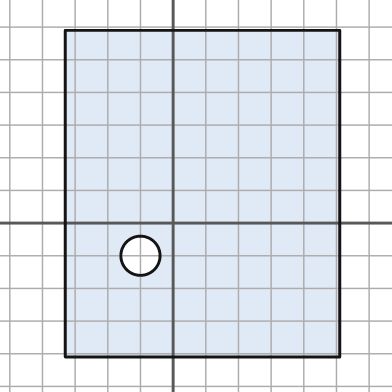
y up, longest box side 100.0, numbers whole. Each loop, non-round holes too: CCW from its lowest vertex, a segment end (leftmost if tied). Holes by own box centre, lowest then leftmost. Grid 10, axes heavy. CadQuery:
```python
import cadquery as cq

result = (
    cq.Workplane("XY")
    .moveTo(-33.0, -41.0)
    .lineTo(51.0, -41.0)
    .lineTo(51.0, 59.0)
    .lineTo(-33.0, 59.0)
    .close()
    .moveTo(-10.0, -10.0)
    .circle(6.0)
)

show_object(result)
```